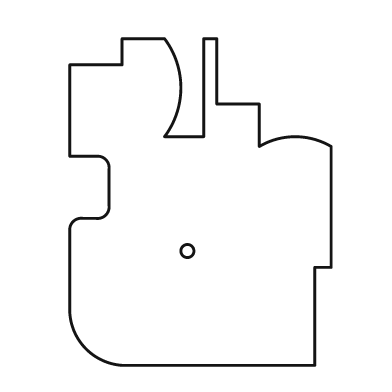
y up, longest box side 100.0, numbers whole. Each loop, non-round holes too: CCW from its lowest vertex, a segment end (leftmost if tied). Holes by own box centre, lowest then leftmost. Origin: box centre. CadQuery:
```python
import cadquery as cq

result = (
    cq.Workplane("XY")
    .moveTo(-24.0, -50.0)
    .lineTo(35.0, -50.0)
    .lineTo(35.0, -20.0)
    .lineTo(40.0, -20.0)
    .lineTo(40.0, 17.0)
    .threePointArc((29.0, 20.0), (18.0, 17.0))
    .lineTo(18.0, 30.0)
    .lineTo(5.0, 30.0)
    .lineTo(5.0, 50.0)
    .lineTo(1.0, 50.0)
    .lineTo(1.0, 20.0)
    .lineTo(-11.0, 20.0)
    .threePointArc((-6.0, 35.0), (-11.0, 50.0))
    .lineTo(-24.0, 50.0)
    .lineTo(-24.0, 42.0)
    .lineTo(-40.0, 42.0)
    .lineTo(-40.0, 14.0)
    .lineTo(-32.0, 14.0)
    .threePointArc((-29.0, 13.0), (-28.0, 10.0))
    .lineTo(-28.0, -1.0)
    .threePointArc((-29.0, -4.0), (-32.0, -5.0))
    .lineTo(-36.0, -5.0)
    .threePointArc((-39.0, -6.0), (-40.0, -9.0))
    .lineTo(-40.0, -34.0)
    .threePointArc((-35.0, -45.0), (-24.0, -50.0))
    .close()
    .moveTo(-4.0, -15.0)
    .circle(2.0)
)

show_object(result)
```